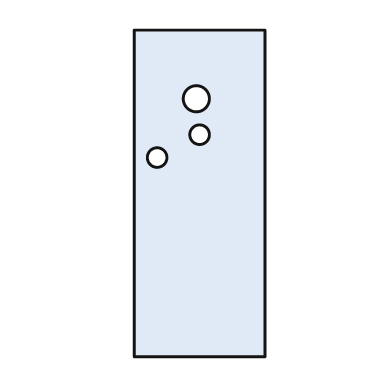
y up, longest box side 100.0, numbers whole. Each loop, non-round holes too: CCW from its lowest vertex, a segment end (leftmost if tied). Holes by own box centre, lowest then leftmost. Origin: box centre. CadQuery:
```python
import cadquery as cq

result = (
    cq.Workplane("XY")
    .moveTo(-20.0, -50.0)
    .lineTo(20.0, -50.0)
    .lineTo(20.0, 50.0)
    .lineTo(-20.0, 50.0)
    .close()
    .moveTo(-13.0, 11.0)
    .circle(3.0)
    .moveTo(0.0, 18.0)
    .circle(3.0)
    .moveTo(-1.0, 29.0)
    .circle(4.0)
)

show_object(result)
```